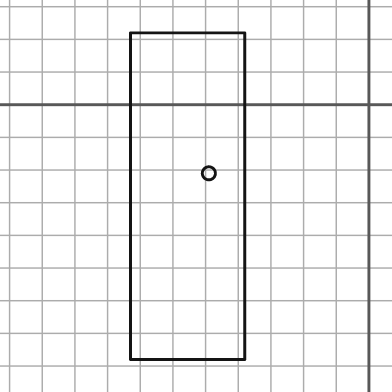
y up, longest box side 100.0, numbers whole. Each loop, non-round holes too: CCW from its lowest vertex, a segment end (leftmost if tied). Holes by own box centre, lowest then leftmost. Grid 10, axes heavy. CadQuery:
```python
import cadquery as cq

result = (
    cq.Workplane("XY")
    .moveTo(-73.0, -78.0)
    .lineTo(-38.0, -78.0)
    .lineTo(-38.0, 22.0)
    .lineTo(-73.0, 22.0)
    .close()
    .moveTo(-49.0, -21.0)
    .circle(2.0)
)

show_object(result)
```